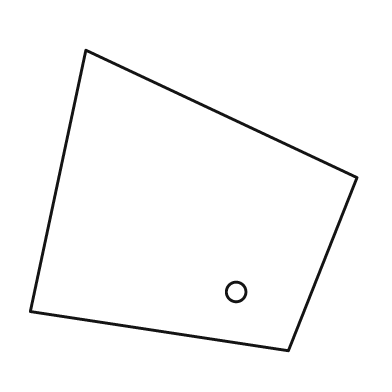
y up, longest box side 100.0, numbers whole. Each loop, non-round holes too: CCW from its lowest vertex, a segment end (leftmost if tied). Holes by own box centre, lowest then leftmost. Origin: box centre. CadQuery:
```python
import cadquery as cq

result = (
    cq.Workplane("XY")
    .moveTo(29.0, -46.0)
    .lineTo(50.0, 7.0)
    .lineTo(-33.0, 46.0)
    .lineTo(-50.0, -34.0)
    .close()
    .moveTo(13.0, -28.0)
    .circle(3.0)
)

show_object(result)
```